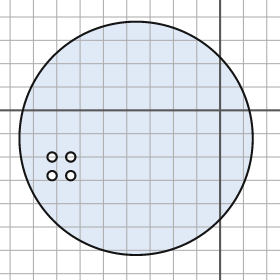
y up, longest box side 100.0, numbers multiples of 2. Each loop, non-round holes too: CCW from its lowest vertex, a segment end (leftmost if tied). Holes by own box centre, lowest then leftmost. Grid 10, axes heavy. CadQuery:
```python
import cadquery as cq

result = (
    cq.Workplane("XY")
    .moveTo(-36.0, -12.0)
    .circle(50.0)
    .moveTo(-72.0, -28.0)
    .circle(2.0)
    .moveTo(-64.0, -28.0)
    .circle(2.0)
    .moveTo(-72.0, -20.0)
    .circle(2.0)
    .moveTo(-64.0, -20.0)
    .circle(2.0)
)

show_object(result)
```